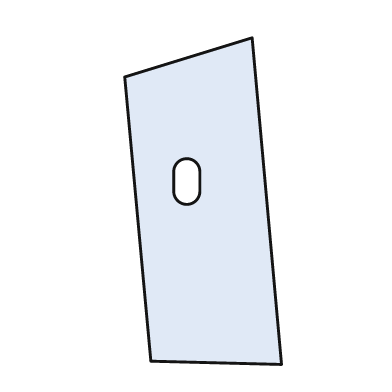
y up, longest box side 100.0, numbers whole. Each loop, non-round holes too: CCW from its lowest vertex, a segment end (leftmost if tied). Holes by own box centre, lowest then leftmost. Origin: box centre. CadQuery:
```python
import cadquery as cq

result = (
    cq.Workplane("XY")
    .moveTo(24.0, -50.0)
    .lineTo(15.0, 50.0)
    .lineTo(-24.0, 38.0)
    .lineTo(-16.0, -49.0)
    .close()
    .moveTo(-9.0, 3.0)
    .threePointArc((-5.0, -1.0), (-1.0, 3.0))
    .lineTo(-1.0, 9.0)
    .threePointArc((-5.0, 13.0), (-9.0, 9.0))
    .close()
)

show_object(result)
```